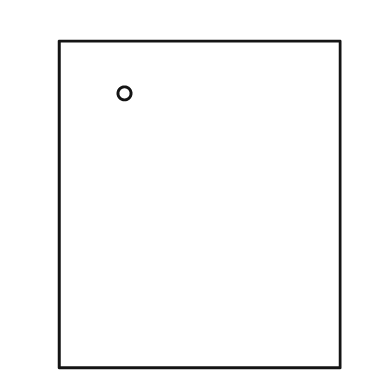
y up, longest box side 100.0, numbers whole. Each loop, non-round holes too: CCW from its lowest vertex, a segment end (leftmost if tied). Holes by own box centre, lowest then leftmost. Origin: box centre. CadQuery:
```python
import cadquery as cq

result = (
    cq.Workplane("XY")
    .moveTo(-43.0, -50.0)
    .lineTo(43.0, -50.0)
    .lineTo(43.0, 50.0)
    .lineTo(-43.0, 50.0)
    .close()
    .moveTo(-23.0, 34.0)
    .circle(2.0)
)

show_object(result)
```